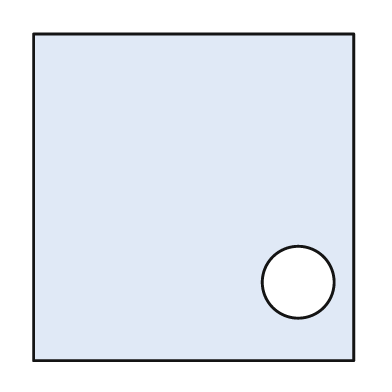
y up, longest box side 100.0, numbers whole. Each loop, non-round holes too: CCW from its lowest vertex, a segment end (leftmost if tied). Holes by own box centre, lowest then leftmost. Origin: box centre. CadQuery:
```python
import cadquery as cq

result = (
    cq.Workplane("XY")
    .moveTo(-49.0, -50.0)
    .lineTo(49.0, -50.0)
    .lineTo(49.0, 50.0)
    .lineTo(-49.0, 50.0)
    .close()
    .moveTo(32.0, -26.0)
    .circle(11.0)
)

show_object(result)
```